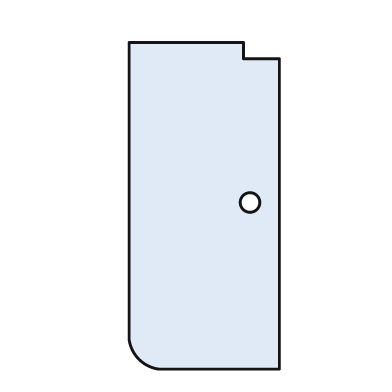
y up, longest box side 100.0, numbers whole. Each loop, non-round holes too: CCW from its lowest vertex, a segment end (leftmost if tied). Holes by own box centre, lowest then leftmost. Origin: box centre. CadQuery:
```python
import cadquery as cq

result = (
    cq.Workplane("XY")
    .moveTo(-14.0, -50.0)
    .lineTo(23.0, -50.0)
    .lineTo(23.0, 45.0)
    .lineTo(12.0, 45.0)
    .lineTo(12.0, 50.0)
    .lineTo(-23.0, 50.0)
    .lineTo(-23.0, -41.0)
    .threePointArc((-20.0, -47.0), (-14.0, -50.0))
    .close()
    .moveTo(14.0, 1.0)
    .circle(3.0)
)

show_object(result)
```